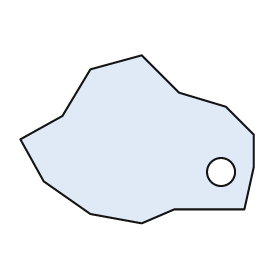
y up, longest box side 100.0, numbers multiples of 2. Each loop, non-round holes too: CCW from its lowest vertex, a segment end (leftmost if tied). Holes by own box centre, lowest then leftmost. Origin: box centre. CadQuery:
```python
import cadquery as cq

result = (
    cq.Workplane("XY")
    .moveTo(2.0, -36.0)
    .lineTo(16.0, -30.0)
    .lineTo(46.0, -30.0)
    .lineTo(50.0, -12.0)
    .lineTo(50.0, 2.0)
    .lineTo(38.0, 14.0)
    .lineTo(18.0, 20.0)
    .lineTo(2.0, 36.0)
    .lineTo(-20.0, 30.0)
    .lineTo(-32.0, 10.0)
    .lineTo(-50.0, 0.0)
    .lineTo(-40.0, -18.0)
    .lineTo(-20.0, -32.0)
    .close()
    .moveTo(36.0, -14.0)
    .circle(6.0)
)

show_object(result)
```